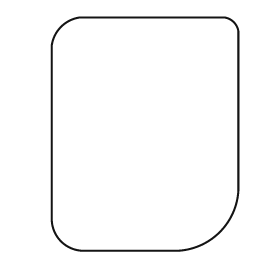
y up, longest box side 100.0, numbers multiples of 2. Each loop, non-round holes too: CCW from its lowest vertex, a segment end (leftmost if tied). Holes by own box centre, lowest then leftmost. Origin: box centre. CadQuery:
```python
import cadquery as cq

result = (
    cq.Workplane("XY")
    .moveTo(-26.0, -50.0)
    .lineTo(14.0, -50.0)
    .threePointArc((32.0, -42.0), (40.0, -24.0))
    .lineTo(40.0, 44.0)
    .threePointArc((38.0, 48.0), (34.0, 50.0))
    .lineTo(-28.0, 50.0)
    .threePointArc((-36.0, 46.0), (-40.0, 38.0))
    .lineTo(-40.0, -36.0)
    .threePointArc((-36.0, -46.0), (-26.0, -50.0))
    .close()
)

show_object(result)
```